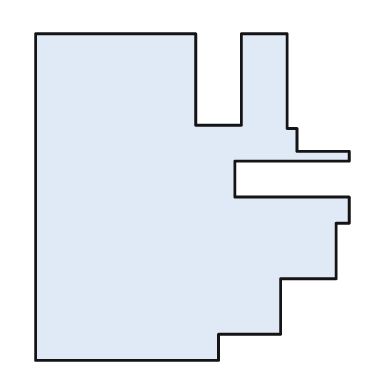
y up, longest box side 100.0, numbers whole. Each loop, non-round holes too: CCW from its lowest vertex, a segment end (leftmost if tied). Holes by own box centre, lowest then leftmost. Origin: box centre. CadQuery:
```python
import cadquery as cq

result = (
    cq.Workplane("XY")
    .moveTo(-48.0, -50.0)
    .lineTo(8.0, -50.0)
    .lineTo(8.0, -42.0)
    .lineTo(27.0, -42.0)
    .lineTo(27.0, -25.0)
    .lineTo(44.0, -25.0)
    .lineTo(44.0, -8.0)
    .lineTo(48.0, -8.0)
    .lineTo(48.0, 0.0)
    .lineTo(13.0, 0.0)
    .lineTo(13.0, 11.0)
    .lineTo(48.0, 11.0)
    .lineTo(48.0, 14.0)
    .lineTo(32.0, 14.0)
    .lineTo(32.0, 21.0)
    .lineTo(29.0, 21.0)
    .lineTo(29.0, 50.0)
    .lineTo(15.0, 50.0)
    .lineTo(15.0, 22.0)
    .lineTo(1.0, 22.0)
    .lineTo(1.0, 50.0)
    .lineTo(-48.0, 50.0)
    .close()
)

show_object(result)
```